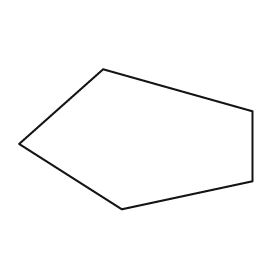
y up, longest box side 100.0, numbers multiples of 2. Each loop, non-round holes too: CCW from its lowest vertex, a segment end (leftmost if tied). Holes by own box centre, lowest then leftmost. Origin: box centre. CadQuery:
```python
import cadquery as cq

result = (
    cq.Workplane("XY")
    .moveTo(-6.0, -30.0)
    .lineTo(50.0, -18.0)
    .lineTo(50.0, 12.0)
    .lineTo(-14.0, 30.0)
    .lineTo(-50.0, -2.0)
    .close()
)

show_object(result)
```